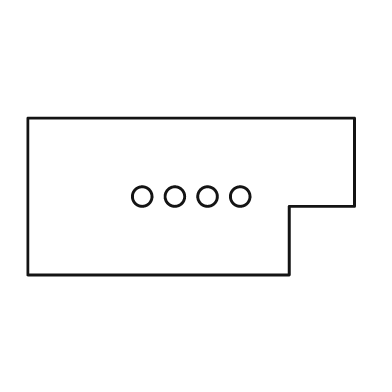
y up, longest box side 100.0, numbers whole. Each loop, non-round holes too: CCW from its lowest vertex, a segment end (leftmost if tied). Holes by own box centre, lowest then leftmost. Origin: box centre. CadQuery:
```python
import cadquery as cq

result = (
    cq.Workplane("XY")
    .moveTo(-50.0, -24.0)
    .lineTo(30.0, -24.0)
    .lineTo(30.0, -3.0)
    .lineTo(50.0, -3.0)
    .lineTo(50.0, 24.0)
    .lineTo(-50.0, 24.0)
    .close()
    .moveTo(-15.0, 0.0)
    .circle(3.0)
    .moveTo(-5.0, 0.0)
    .circle(3.0)
    .moveTo(5.0, 0.0)
    .circle(3.0)
    .moveTo(15.0, 0.0)
    .circle(3.0)
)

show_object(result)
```